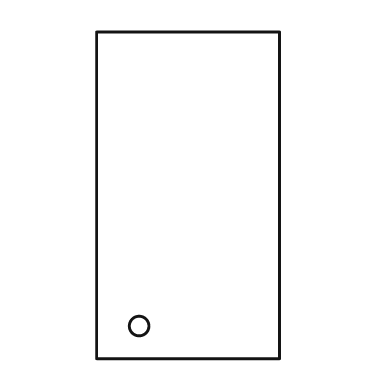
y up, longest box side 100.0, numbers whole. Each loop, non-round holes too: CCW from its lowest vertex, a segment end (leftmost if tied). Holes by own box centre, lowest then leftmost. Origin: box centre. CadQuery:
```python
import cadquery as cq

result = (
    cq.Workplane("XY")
    .moveTo(-28.0, -50.0)
    .lineTo(28.0, -50.0)
    .lineTo(28.0, 50.0)
    .lineTo(-28.0, 50.0)
    .close()
    .moveTo(-15.0, -40.0)
    .circle(3.0)
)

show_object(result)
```